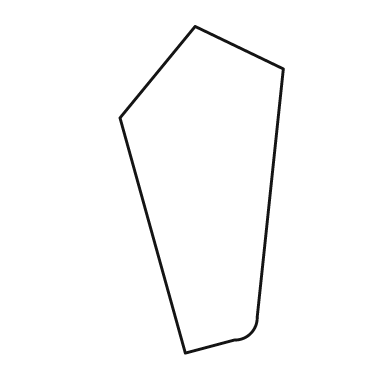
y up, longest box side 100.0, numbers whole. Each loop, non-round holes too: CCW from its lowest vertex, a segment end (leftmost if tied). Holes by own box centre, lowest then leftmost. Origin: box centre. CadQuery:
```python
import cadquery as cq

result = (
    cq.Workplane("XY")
    .moveTo(-5.0, -50.0)
    .lineTo(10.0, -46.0)
    .threePointArc((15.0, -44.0), (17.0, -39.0))
    .lineTo(25.0, 37.0)
    .lineTo(-2.0, 50.0)
    .lineTo(-25.0, 22.0)
    .close()
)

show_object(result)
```